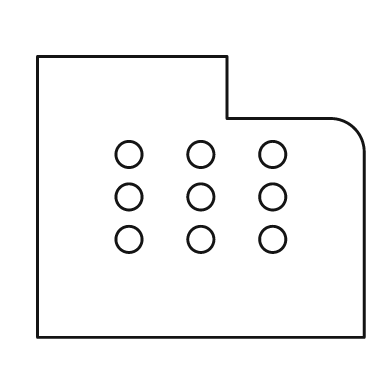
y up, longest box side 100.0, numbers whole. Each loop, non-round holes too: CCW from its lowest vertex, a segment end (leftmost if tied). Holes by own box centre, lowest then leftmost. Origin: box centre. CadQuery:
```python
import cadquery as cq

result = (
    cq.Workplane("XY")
    .moveTo(-50.0, -43.0)
    .lineTo(50.0, -43.0)
    .lineTo(50.0, 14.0)
    .threePointArc((47.0, 21.0), (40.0, 24.0))
    .lineTo(8.0, 24.0)
    .lineTo(8.0, 43.0)
    .lineTo(-50.0, 43.0)
    .close()
    .moveTo(-22.0, -13.0)
    .circle(4.0)
    .moveTo(0.0, -13.0)
    .circle(4.0)
    .moveTo(22.0, -13.0)
    .circle(4.0)
    .moveTo(-22.0, 0.0)
    .circle(4.0)
    .moveTo(0.0, 0.0)
    .circle(4.0)
    .moveTo(22.0, 0.0)
    .circle(4.0)
    .moveTo(-22.0, 13.0)
    .circle(4.0)
    .moveTo(0.0, 13.0)
    .circle(4.0)
    .moveTo(22.0, 13.0)
    .circle(4.0)
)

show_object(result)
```